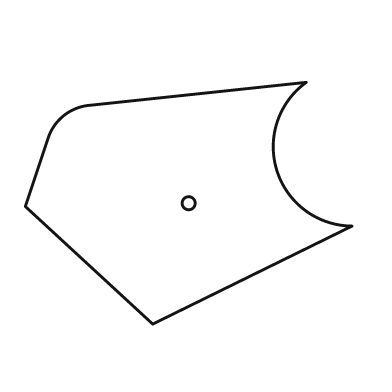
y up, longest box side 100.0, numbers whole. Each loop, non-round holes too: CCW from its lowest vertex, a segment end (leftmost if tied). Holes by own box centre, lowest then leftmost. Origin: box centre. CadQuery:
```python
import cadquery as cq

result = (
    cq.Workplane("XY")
    .moveTo(-11.0, -37.0)
    .lineTo(50.0, -7.0)
    .threePointArc((27.0, 10.0), (36.0, 37.0))
    .lineTo(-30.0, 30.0)
    .threePointArc((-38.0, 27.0), (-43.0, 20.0))
    .lineTo(-50.0, -1.0)
    .close()
    .moveTo(0.0, 0.0)
    .circle(2.0)
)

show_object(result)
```